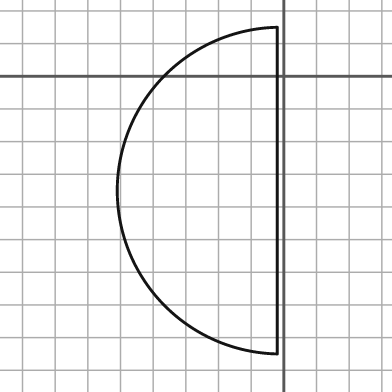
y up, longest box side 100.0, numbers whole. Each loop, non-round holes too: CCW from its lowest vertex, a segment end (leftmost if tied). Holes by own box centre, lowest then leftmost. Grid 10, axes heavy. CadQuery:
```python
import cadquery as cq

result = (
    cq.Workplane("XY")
    .moveTo(-2.0, -85.0)
    .lineTo(-2.0, 15.0)
    .threePointArc((-51.0, -35.0), (-2.0, -85.0))
    .close()
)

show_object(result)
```